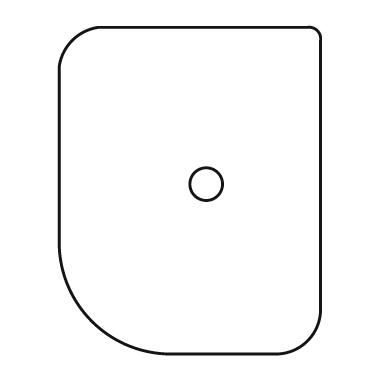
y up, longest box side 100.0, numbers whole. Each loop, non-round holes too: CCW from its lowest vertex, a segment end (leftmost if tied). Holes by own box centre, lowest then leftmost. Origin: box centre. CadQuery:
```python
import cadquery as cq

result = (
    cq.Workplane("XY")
    .moveTo(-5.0, -50.0)
    .lineTo(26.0, -50.0)
    .threePointArc((36.0, -46.0), (40.0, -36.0))
    .lineTo(40.0, 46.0)
    .threePointArc((39.0, 49.0), (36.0, 50.0))
    .lineTo(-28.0, 50.0)
    .threePointArc((-36.0, 46.0), (-40.0, 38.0))
    .lineTo(-40.0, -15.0)
    .threePointArc((-30.0, -40.0), (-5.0, -50.0))
    .close()
    .moveTo(5.0, 2.0)
    .circle(5.0)
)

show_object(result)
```